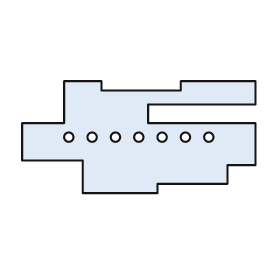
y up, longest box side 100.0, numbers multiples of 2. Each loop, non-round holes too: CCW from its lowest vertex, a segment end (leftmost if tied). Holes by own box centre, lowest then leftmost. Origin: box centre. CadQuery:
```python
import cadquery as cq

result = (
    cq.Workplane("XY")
    .moveTo(-24.0, -24.0)
    .lineTo(8.0, -24.0)
    .lineTo(8.0, -20.0)
    .lineTo(38.0, -20.0)
    .lineTo(38.0, -12.0)
    .lineTo(50.0, -12.0)
    .lineTo(50.0, 6.0)
    .lineTo(4.0, 6.0)
    .lineTo(4.0, 14.0)
    .lineTo(50.0, 14.0)
    .lineTo(50.0, 24.0)
    .lineTo(18.0, 24.0)
    .lineTo(18.0, 20.0)
    .lineTo(-16.0, 20.0)
    .lineTo(-16.0, 24.0)
    .lineTo(-32.0, 24.0)
    .lineTo(-32.0, 6.0)
    .lineTo(-50.0, 6.0)
    .lineTo(-50.0, -10.0)
    .lineTo(-24.0, -10.0)
    .close()
    .moveTo(-30.0, 0.0)
    .circle(2.0)
    .moveTo(-20.0, 0.0)
    .circle(2.0)
    .moveTo(-10.0, 0.0)
    .circle(2.0)
    .moveTo(0.0, 0.0)
    .circle(2.0)
    .moveTo(10.0, 0.0)
    .circle(2.0)
    .moveTo(20.0, 0.0)
    .circle(2.0)
    .moveTo(30.0, 0.0)
    .circle(2.0)
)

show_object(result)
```